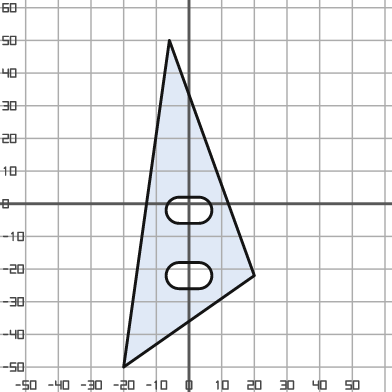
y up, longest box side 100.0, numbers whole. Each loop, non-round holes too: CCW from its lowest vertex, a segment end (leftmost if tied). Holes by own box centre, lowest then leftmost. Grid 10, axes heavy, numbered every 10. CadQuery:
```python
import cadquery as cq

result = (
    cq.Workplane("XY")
    .moveTo(-20.0, -50.0)
    .lineTo(20.0, -22.0)
    .lineTo(-6.0, 50.0)
    .close()
    .moveTo(-3.0, -26.0)
    .lineTo(3.0, -26.0)
    .threePointArc((7.0, -22.0), (3.0, -18.0))
    .lineTo(-3.0, -18.0)
    .threePointArc((-7.0, -22.0), (-3.0, -26.0))
    .close()
    .moveTo(-3.0, -6.0)
    .lineTo(3.0, -6.0)
    .threePointArc((7.0, -2.0), (3.0, 2.0))
    .lineTo(-3.0, 2.0)
    .threePointArc((-7.0, -2.0), (-3.0, -6.0))
    .close()
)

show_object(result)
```